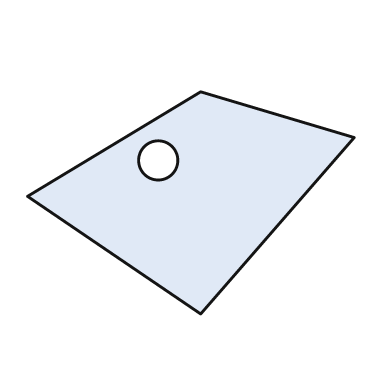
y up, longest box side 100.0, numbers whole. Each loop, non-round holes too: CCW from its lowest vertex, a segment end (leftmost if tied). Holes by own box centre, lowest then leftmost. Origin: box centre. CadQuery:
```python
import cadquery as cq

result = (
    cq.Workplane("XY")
    .moveTo(3.0, -34.0)
    .lineTo(50.0, 20.0)
    .lineTo(3.0, 34.0)
    .lineTo(-50.0, 2.0)
    .close()
    .moveTo(-10.0, 13.0)
    .circle(6.0)
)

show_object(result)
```